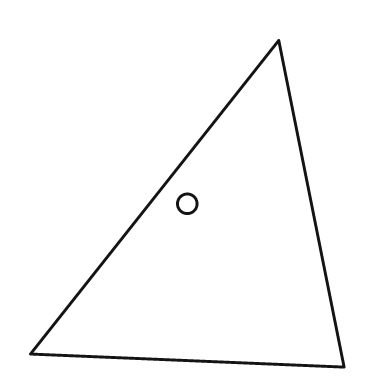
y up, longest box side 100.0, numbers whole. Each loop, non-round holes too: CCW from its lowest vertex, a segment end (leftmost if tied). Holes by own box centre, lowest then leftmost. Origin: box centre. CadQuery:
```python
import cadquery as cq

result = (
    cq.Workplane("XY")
    .moveTo(48.0, -50.0)
    .lineTo(28.0, 50.0)
    .lineTo(-48.0, -46.0)
    .close()
    .moveTo(0.0, 0.0)
    .circle(3.0)
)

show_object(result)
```